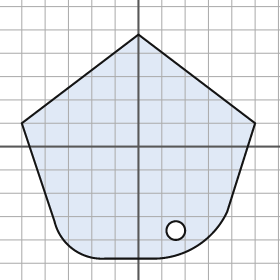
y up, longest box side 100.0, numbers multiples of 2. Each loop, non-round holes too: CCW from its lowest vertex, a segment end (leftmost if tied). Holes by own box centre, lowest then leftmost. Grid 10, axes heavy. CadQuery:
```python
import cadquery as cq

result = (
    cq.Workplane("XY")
    .moveTo(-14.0, -48.0)
    .lineTo(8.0, -48.0)
    .threePointArc((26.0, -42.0), (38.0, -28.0))
    .lineTo(50.0, 10.0)
    .lineTo(0.0, 48.0)
    .lineTo(-50.0, 10.0)
    .lineTo(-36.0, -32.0)
    .threePointArc((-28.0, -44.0), (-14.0, -48.0))
    .close()
    .moveTo(16.0, -36.0)
    .circle(4.0)
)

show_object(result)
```